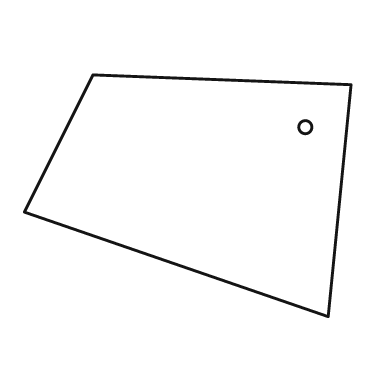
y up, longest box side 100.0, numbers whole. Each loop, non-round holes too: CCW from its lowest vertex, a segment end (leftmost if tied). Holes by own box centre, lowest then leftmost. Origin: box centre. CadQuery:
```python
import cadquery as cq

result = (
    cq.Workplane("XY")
    .moveTo(43.0, -37.0)
    .lineTo(50.0, 34.0)
    .lineTo(-29.0, 37.0)
    .lineTo(-50.0, -5.0)
    .close()
    .moveTo(36.0, 21.0)
    .circle(2.0)
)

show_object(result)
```